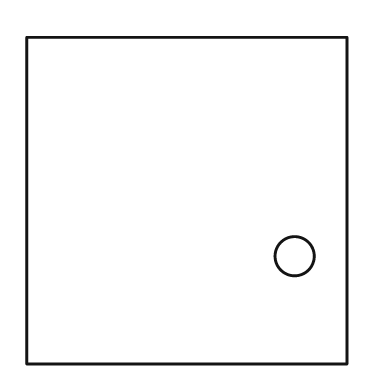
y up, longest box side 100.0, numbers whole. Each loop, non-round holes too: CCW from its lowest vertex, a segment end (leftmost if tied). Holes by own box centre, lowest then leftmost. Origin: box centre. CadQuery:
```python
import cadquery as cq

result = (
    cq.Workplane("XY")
    .moveTo(-49.0, -50.0)
    .lineTo(49.0, -50.0)
    .lineTo(49.0, 50.0)
    .lineTo(-49.0, 50.0)
    .close()
    .moveTo(33.0, -17.0)
    .circle(6.0)
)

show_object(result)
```